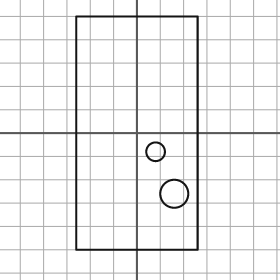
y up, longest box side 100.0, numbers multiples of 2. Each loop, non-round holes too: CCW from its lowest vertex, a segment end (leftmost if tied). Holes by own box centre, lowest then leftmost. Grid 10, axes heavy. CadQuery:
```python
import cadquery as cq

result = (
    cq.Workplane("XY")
    .moveTo(-26.0, -50.0)
    .lineTo(26.0, -50.0)
    .lineTo(26.0, 50.0)
    .lineTo(-26.0, 50.0)
    .close()
    .moveTo(16.0, -26.0)
    .circle(6.0)
    .moveTo(8.0, -8.0)
    .circle(4.0)
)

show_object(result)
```